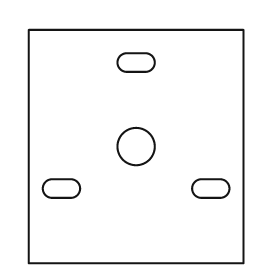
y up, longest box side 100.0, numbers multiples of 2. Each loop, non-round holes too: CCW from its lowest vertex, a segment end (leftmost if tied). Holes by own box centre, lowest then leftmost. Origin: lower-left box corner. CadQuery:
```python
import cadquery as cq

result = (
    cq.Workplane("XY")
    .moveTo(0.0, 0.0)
    .lineTo(92.0, 0.0)
    .lineTo(92.0, 100.0)
    .lineTo(0.0, 100.0)
    .close()
    .moveTo(10.0, 28.0)
    .lineTo(18.0, 28.0)
    .threePointArc((22.0, 32.0), (18.0, 36.0))
    .lineTo(10.0, 36.0)
    .threePointArc((6.0, 32.0), (10.0, 28.0))
    .close()
    .moveTo(74.0, 28.0)
    .lineTo(82.0, 28.0)
    .threePointArc((86.0, 32.0), (82.0, 36.0))
    .lineTo(74.0, 36.0)
    .threePointArc((70.0, 32.0), (74.0, 28.0))
    .close()
    .moveTo(46.0, 50.0)
    .circle(8.0)
    .moveTo(42.0, 82.0)
    .lineTo(50.0, 82.0)
    .threePointArc((54.0, 86.0), (50.0, 90.0))
    .lineTo(42.0, 90.0)
    .threePointArc((38.0, 86.0), (42.0, 82.0))
    .close()
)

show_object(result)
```